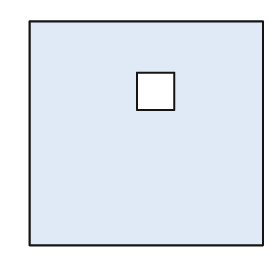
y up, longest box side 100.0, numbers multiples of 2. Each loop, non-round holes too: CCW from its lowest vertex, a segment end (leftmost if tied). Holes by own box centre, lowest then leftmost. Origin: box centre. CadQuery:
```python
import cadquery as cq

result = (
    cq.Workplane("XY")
    .moveTo(-50.0, -48.0)
    .lineTo(50.0, -48.0)
    .lineTo(50.0, 48.0)
    .lineTo(-50.0, 48.0)
    .close()
    .moveTo(-4.0, 10.0)
    .lineTo(12.0, 10.0)
    .lineTo(12.0, 26.0)
    .lineTo(-4.0, 26.0)
    .close()
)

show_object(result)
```